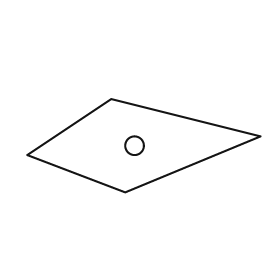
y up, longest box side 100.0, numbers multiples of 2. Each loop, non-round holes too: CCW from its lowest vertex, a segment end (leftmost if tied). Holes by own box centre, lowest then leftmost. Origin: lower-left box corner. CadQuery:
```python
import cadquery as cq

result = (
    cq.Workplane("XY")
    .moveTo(42.0, 0.0)
    .lineTo(100.0, 24.0)
    .lineTo(36.0, 40.0)
    .lineTo(0.0, 16.0)
    .close()
    .moveTo(46.0, 20.0)
    .circle(4.0)
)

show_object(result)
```